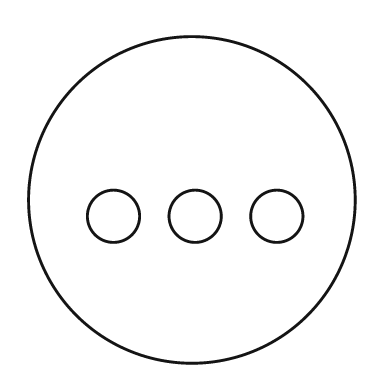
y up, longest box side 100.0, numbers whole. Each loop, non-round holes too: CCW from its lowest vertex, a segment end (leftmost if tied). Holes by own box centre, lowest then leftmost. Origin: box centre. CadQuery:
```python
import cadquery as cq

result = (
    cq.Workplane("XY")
    .moveTo(0.0, 0.0)
    .circle(50.0)
    .moveTo(-24.0, -5.0)
    .circle(8.0)
    .moveTo(1.0, -5.0)
    .circle(8.0)
    .moveTo(26.0, -5.0)
    .circle(8.0)
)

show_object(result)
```